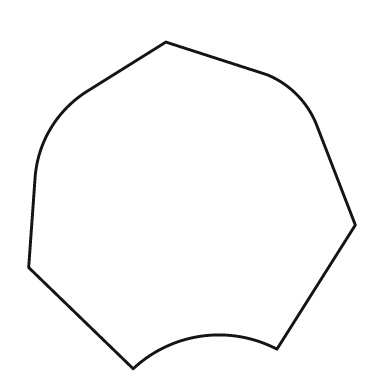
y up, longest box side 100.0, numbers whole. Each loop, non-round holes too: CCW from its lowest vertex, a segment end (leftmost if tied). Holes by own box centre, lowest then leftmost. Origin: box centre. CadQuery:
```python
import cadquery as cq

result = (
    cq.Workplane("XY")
    .moveTo(-18.0, -50.0)
    .threePointArc((3.0, -40.0), (26.0, -44.0))
    .lineTo(50.0, -6.0)
    .lineTo(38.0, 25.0)
    .threePointArc((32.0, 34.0), (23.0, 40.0))
    .lineTo(-8.0, 50.0)
    .lineTo(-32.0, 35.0)
    .threePointArc((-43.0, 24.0), (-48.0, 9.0))
    .lineTo(-50.0, -19.0)
    .close()
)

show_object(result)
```